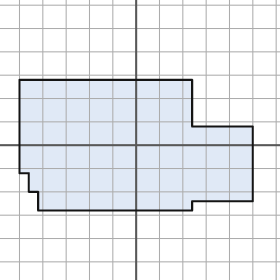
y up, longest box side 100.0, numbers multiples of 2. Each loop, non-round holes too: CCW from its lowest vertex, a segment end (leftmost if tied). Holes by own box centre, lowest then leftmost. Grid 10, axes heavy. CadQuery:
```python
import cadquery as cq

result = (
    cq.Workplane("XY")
    .moveTo(-42.0, -28.0)
    .lineTo(24.0, -28.0)
    .lineTo(24.0, -24.0)
    .lineTo(50.0, -24.0)
    .lineTo(50.0, 8.0)
    .lineTo(24.0, 8.0)
    .lineTo(24.0, 28.0)
    .lineTo(-50.0, 28.0)
    .lineTo(-50.0, -12.0)
    .lineTo(-46.0, -12.0)
    .lineTo(-46.0, -20.0)
    .lineTo(-42.0, -20.0)
    .close()
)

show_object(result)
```